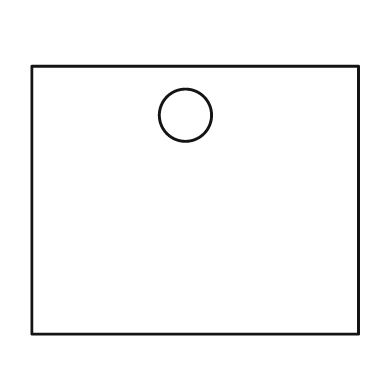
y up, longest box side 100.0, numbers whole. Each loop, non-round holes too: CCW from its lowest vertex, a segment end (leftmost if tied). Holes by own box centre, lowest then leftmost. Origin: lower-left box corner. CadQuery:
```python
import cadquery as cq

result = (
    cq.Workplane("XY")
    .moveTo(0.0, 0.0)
    .lineTo(100.0, 0.0)
    .lineTo(100.0, 82.0)
    .lineTo(0.0, 82.0)
    .close()
    .moveTo(47.0, 67.0)
    .circle(8.0)
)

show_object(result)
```